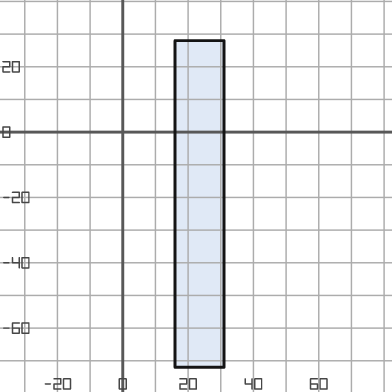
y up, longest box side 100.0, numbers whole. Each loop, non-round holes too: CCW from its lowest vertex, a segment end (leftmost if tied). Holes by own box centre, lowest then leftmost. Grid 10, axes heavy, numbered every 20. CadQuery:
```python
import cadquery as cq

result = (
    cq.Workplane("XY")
    .moveTo(16.0, -72.0)
    .lineTo(31.0, -72.0)
    .lineTo(31.0, 28.0)
    .lineTo(16.0, 28.0)
    .close()
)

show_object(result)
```